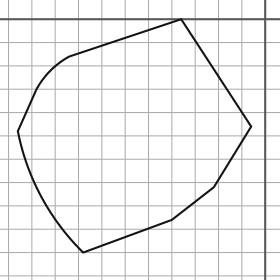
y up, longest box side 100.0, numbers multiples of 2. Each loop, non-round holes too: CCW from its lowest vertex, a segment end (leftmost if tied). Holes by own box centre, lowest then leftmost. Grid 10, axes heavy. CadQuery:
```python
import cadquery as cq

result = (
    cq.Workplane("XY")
    .moveTo(-78.0, -100.0)
    .lineTo(-40.0, -86.0)
    .lineTo(-22.0, -72.0)
    .lineTo(-6.0, -46.0)
    .lineTo(-36.0, 0.0)
    .lineTo(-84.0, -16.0)
    .threePointArc((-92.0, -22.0), (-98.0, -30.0))
    .lineTo(-106.0, -48.0)
    .threePointArc((-96.0, -76.0), (-78.0, -100.0))
    .close()
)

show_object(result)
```